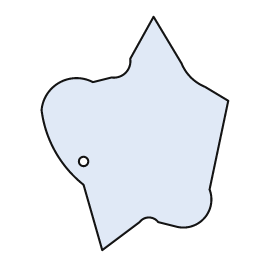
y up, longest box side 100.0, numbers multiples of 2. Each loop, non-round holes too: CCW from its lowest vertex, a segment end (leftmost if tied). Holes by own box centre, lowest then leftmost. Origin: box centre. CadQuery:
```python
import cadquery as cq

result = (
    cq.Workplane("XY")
    .moveTo(-14.0, -50.0)
    .lineTo(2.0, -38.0)
    .threePointArc((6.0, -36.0), (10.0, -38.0))
    .lineTo(18.0, -40.0)
    .threePointArc((30.0, -36.0), (32.0, -24.0))
    .lineTo(40.0, 14.0)
    .lineTo(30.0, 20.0)
    .threePointArc((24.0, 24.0), (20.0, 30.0))
    .lineTo(8.0, 50.0)
    .lineTo(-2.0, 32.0)
    .threePointArc((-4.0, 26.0), (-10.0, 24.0))
    .lineTo(-18.0, 22.0)
    .threePointArc((-32.0, 22.0), (-40.0, 10.0))
    .threePointArc((-34.0, -8.0), (-22.0, -22.0))
    .close()
    .moveTo(-22.0, -12.0)
    .circle(2.0)
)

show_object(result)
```